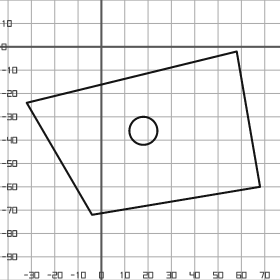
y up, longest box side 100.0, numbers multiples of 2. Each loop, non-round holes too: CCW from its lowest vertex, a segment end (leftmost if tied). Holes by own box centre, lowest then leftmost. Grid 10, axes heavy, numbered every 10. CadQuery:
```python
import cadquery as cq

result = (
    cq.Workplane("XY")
    .moveTo(-4.0, -72.0)
    .lineTo(68.0, -60.0)
    .lineTo(58.0, -2.0)
    .lineTo(-32.0, -24.0)
    .close()
    .moveTo(18.0, -36.0)
    .circle(6.0)
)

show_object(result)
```